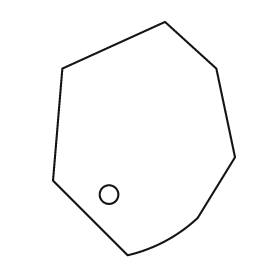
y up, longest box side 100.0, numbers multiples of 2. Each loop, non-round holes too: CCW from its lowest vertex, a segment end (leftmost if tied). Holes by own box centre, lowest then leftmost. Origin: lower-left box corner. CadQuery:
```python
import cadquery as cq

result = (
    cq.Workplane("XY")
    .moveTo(32.0, 0.0)
    .threePointArc((48.0, 6.0), (62.0, 16.0))
    .lineTo(78.0, 42.0)
    .lineTo(70.0, 80.0)
    .lineTo(48.0, 100.0)
    .lineTo(4.0, 80.0)
    .lineTo(0.0, 32.0)
    .close()
    .moveTo(24.0, 26.0)
    .circle(4.0)
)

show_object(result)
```